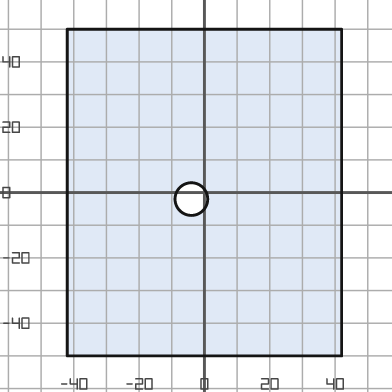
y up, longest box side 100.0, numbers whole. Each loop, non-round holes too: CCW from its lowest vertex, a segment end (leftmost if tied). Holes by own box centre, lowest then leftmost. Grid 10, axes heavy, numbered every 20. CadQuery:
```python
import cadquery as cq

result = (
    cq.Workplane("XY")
    .moveTo(-42.0, -50.0)
    .lineTo(42.0, -50.0)
    .lineTo(42.0, 50.0)
    .lineTo(-42.0, 50.0)
    .close()
    .moveTo(-4.0, -2.0)
    .circle(5.0)
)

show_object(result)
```